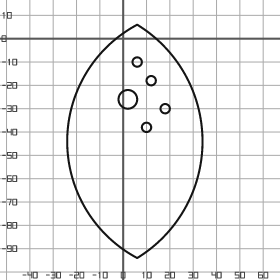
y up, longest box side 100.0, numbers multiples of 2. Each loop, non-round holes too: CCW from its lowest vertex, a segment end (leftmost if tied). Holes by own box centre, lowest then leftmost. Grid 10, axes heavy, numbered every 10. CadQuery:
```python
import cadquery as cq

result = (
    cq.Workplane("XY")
    .moveTo(6.0, -94.0)
    .threePointArc((34.0, -44.0), (6.0, 6.0))
    .threePointArc((-24.0, -44.0), (6.0, -94.0))
    .close()
    .moveTo(10.0, -38.0)
    .circle(2.0)
    .moveTo(18.0, -30.0)
    .circle(2.0)
    .moveTo(2.0, -26.0)
    .circle(4.0)
    .moveTo(12.0, -18.0)
    .circle(2.0)
    .moveTo(6.0, -10.0)
    .circle(2.0)
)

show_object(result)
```